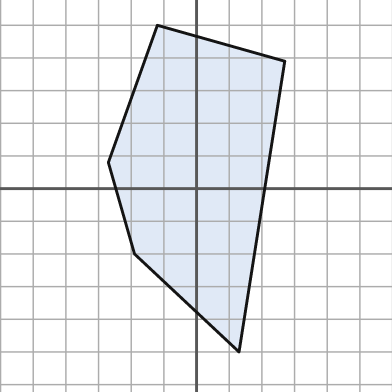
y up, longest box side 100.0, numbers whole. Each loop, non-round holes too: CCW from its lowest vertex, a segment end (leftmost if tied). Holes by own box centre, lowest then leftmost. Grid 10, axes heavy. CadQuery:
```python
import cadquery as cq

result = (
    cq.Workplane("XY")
    .moveTo(13.0, -50.0)
    .lineTo(27.0, 39.0)
    .lineTo(-12.0, 50.0)
    .lineTo(-27.0, 8.0)
    .lineTo(-19.0, -20.0)
    .close()
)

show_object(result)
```